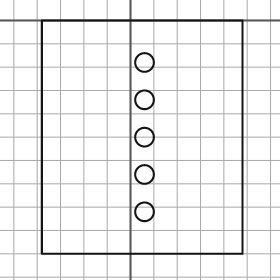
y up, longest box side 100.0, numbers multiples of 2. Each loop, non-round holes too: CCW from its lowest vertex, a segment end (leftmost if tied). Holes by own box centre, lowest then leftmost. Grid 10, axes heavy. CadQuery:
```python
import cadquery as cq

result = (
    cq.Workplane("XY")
    .moveTo(-38.0, -100.0)
    .lineTo(48.0, -100.0)
    .lineTo(48.0, 0.0)
    .lineTo(-38.0, 0.0)
    .close()
    .moveTo(6.0, -82.0)
    .circle(4.0)
    .moveTo(6.0, -66.0)
    .circle(4.0)
    .moveTo(6.0, -50.0)
    .circle(4.0)
    .moveTo(6.0, -34.0)
    .circle(4.0)
    .moveTo(6.0, -18.0)
    .circle(4.0)
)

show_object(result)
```